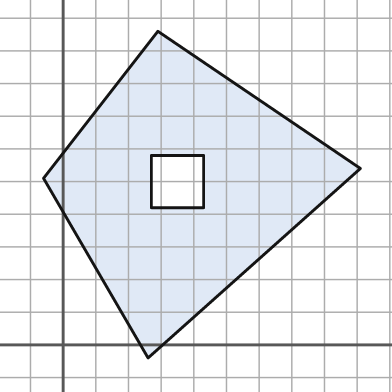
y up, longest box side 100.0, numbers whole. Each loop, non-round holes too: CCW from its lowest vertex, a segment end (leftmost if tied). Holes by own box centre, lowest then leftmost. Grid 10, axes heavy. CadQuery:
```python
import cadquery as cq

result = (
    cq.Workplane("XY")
    .moveTo(26.0, -4.0)
    .lineTo(91.0, 54.0)
    .lineTo(29.0, 96.0)
    .lineTo(-6.0, 51.0)
    .close()
    .moveTo(27.0, 42.0)
    .lineTo(43.0, 42.0)
    .lineTo(43.0, 58.0)
    .lineTo(27.0, 58.0)
    .close()
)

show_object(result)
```